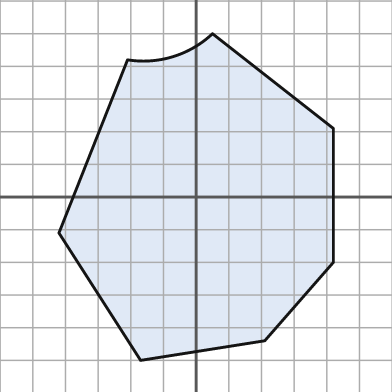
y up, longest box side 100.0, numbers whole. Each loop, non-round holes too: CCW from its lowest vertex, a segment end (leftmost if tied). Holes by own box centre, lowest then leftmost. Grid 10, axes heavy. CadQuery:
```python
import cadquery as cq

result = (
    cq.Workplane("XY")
    .moveTo(-17.0, -50.0)
    .lineTo(21.0, -44.0)
    .lineTo(42.0, -20.0)
    .lineTo(42.0, 21.0)
    .lineTo(5.0, 50.0)
    .threePointArc((-7.0, 43.0), (-21.0, 42.0))
    .lineTo(-42.0, -11.0)
    .close()
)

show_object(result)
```